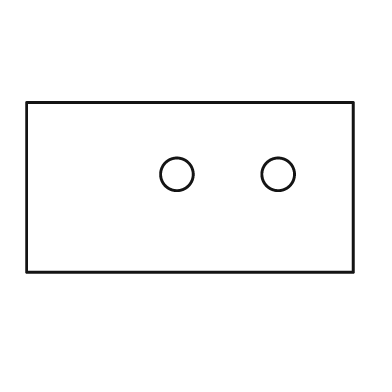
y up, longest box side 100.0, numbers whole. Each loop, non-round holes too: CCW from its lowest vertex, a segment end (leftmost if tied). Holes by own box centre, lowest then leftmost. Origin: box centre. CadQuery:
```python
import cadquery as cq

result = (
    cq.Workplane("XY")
    .moveTo(-50.0, -26.0)
    .lineTo(50.0, -26.0)
    .lineTo(50.0, 26.0)
    .lineTo(-50.0, 26.0)
    .close()
    .moveTo(-4.0, 4.0)
    .circle(5.0)
    .moveTo(27.0, 4.0)
    .circle(5.0)
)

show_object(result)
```